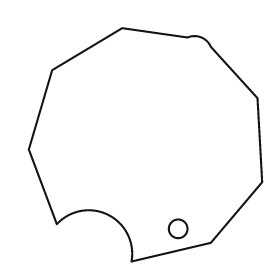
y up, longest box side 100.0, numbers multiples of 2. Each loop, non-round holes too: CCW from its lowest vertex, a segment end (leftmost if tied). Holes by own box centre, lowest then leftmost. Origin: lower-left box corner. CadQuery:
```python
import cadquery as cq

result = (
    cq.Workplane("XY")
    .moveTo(44.0, 0.0)
    .lineTo(78.0, 8.0)
    .lineTo(100.0, 34.0)
    .lineTo(98.0, 70.0)
    .lineTo(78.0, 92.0)
    .threePointArc((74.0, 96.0), (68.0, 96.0))
    .lineTo(40.0, 100.0)
    .lineTo(10.0, 82.0)
    .lineTo(0.0, 48.0)
    .lineTo(12.0, 16.0)
    .threePointArc((34.0, 20.0), (44.0, 0.0))
    .close()
    .moveTo(64.0, 14.0)
    .circle(4.0)
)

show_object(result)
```